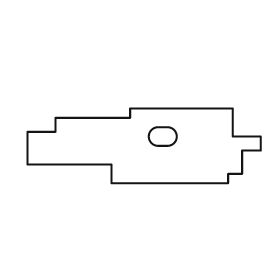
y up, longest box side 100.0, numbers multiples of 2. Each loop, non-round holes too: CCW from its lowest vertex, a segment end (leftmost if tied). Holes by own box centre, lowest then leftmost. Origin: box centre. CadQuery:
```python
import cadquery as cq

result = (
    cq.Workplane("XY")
    .moveTo(-14.0, -16.0)
    .lineTo(36.0, -16.0)
    .lineTo(36.0, -12.0)
    .lineTo(42.0, -12.0)
    .lineTo(42.0, -2.0)
    .lineTo(50.0, -2.0)
    .lineTo(50.0, 4.0)
    .lineTo(38.0, 4.0)
    .lineTo(38.0, 16.0)
    .lineTo(-6.0, 16.0)
    .lineTo(-6.0, 12.0)
    .lineTo(-38.0, 12.0)
    .lineTo(-38.0, 6.0)
    .lineTo(-50.0, 6.0)
    .lineTo(-50.0, -8.0)
    .lineTo(-14.0, -8.0)
    .close()
    .moveTo(6.0, 0.0)
    .lineTo(10.0, 0.0)
    .threePointArc((14.0, 4.0), (10.0, 8.0))
    .lineTo(6.0, 8.0)
    .threePointArc((2.0, 4.0), (6.0, 0.0))
    .close()
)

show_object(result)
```